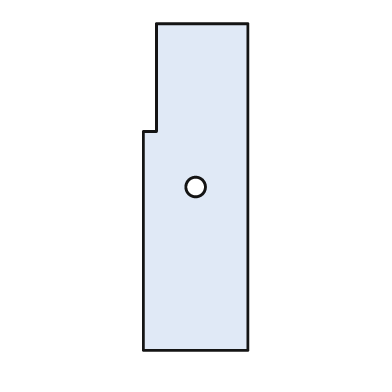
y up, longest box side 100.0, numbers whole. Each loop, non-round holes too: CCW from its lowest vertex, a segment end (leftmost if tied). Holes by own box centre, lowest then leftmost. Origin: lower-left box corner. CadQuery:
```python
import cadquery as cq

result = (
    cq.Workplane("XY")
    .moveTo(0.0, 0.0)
    .lineTo(32.0, 0.0)
    .lineTo(32.0, 100.0)
    .lineTo(4.0, 100.0)
    .lineTo(4.0, 67.0)
    .lineTo(0.0, 67.0)
    .close()
    .moveTo(16.0, 50.0)
    .circle(3.0)
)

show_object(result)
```